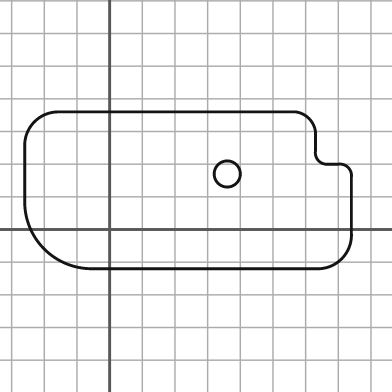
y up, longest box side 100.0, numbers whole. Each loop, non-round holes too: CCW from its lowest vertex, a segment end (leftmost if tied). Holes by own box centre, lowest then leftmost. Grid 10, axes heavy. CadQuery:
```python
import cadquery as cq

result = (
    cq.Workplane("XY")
    .moveTo(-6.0, -12.0)
    .lineTo(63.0, -12.0)
    .threePointArc((71.0, -9.0), (74.0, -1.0))
    .lineTo(74.0, 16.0)
    .threePointArc((73.0, 19.0), (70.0, 20.0))
    .lineTo(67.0, 20.0)
    .threePointArc((64.0, 21.0), (63.0, 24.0))
    .lineTo(63.0, 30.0)
    .threePointArc((61.0, 34.0), (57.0, 36.0))
    .lineTo(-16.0, 36.0)
    .threePointArc((-23.0, 33.0), (-26.0, 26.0))
    .lineTo(-26.0, 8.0)
    .threePointArc((-20.0, -6.0), (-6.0, -12.0))
    .close()
    .moveTo(36.0, 17.0)
    .circle(4.0)
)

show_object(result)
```